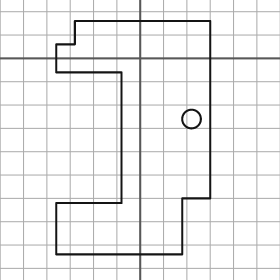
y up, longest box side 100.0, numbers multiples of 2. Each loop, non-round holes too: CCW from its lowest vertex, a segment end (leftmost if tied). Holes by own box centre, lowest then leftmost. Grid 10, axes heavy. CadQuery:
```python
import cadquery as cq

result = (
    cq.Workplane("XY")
    .moveTo(-36.0, -84.0)
    .lineTo(18.0, -84.0)
    .lineTo(18.0, -60.0)
    .lineTo(30.0, -60.0)
    .lineTo(30.0, 16.0)
    .lineTo(-28.0, 16.0)
    .lineTo(-28.0, 6.0)
    .lineTo(-36.0, 6.0)
    .lineTo(-36.0, -6.0)
    .lineTo(-8.0, -6.0)
    .lineTo(-8.0, -62.0)
    .lineTo(-36.0, -62.0)
    .close()
    .moveTo(22.0, -26.0)
    .circle(4.0)
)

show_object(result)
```